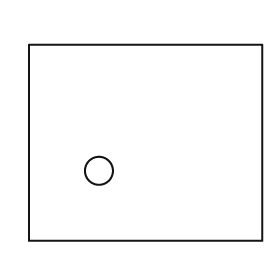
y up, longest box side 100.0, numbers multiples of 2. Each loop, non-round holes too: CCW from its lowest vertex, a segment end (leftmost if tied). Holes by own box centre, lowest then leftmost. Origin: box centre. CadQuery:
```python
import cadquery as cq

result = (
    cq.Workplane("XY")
    .moveTo(-50.0, -42.0)
    .lineTo(50.0, -42.0)
    .lineTo(50.0, 42.0)
    .lineTo(-50.0, 42.0)
    .close()
    .moveTo(-20.0, -12.0)
    .circle(6.0)
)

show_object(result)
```